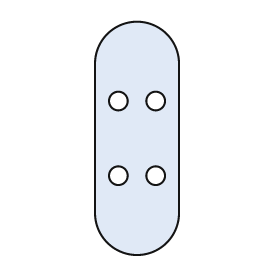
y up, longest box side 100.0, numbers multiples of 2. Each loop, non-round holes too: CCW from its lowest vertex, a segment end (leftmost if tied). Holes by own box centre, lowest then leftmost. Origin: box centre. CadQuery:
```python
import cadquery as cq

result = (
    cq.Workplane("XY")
    .moveTo(-18.0, -32.0)
    .threePointArc((0.0, -50.0), (18.0, -32.0))
    .lineTo(18.0, 32.0)
    .threePointArc((0.0, 50.0), (-18.0, 32.0))
    .close()
    .moveTo(-8.0, -16.0)
    .circle(4.0)
    .moveTo(8.0, -16.0)
    .circle(4.0)
    .moveTo(-8.0, 16.0)
    .circle(4.0)
    .moveTo(8.0, 16.0)
    .circle(4.0)
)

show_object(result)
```